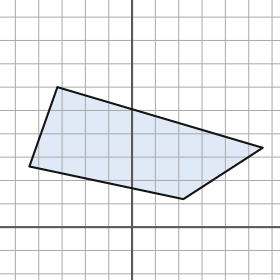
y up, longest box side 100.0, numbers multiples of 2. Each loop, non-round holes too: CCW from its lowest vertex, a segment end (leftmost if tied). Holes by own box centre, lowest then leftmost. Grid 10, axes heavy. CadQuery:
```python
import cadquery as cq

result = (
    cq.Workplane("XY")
    .moveTo(22.0, 12.0)
    .lineTo(56.0, 34.0)
    .lineTo(-32.0, 60.0)
    .lineTo(-44.0, 26.0)
    .close()
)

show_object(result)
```